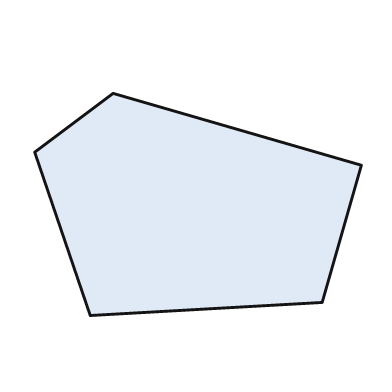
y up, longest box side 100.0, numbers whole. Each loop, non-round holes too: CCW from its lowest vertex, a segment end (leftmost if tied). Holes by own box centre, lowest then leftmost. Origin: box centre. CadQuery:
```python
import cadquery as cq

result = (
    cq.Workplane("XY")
    .moveTo(-33.0, -34.0)
    .lineTo(38.0, -30.0)
    .lineTo(50.0, 12.0)
    .lineTo(-26.0, 34.0)
    .lineTo(-50.0, 16.0)
    .close()
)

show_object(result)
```